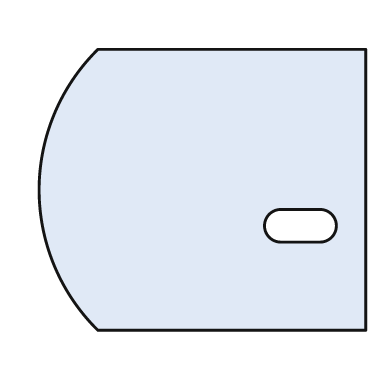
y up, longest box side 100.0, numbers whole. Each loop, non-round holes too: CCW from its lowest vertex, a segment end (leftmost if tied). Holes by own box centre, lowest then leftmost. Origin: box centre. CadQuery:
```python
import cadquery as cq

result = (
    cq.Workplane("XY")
    .moveTo(-32.0, -43.0)
    .lineTo(50.0, -43.0)
    .lineTo(50.0, 43.0)
    .lineTo(-32.0, 43.0)
    .threePointArc((-50.0, 0.0), (-32.0, -43.0))
    .close()
    .moveTo(24.0, -16.0)
    .lineTo(36.0, -16.0)
    .threePointArc((41.0, -11.0), (36.0, -6.0))
    .lineTo(24.0, -6.0)
    .threePointArc((19.0, -11.0), (24.0, -16.0))
    .close()
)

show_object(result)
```